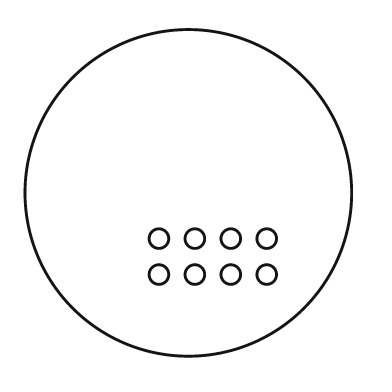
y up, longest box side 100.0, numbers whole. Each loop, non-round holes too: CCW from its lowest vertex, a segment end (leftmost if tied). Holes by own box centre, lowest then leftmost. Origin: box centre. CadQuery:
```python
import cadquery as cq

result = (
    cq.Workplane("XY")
    .moveTo(0.0, 0.0)
    .circle(50.0)
    .moveTo(-9.0, -25.0)
    .circle(3.0)
    .moveTo(2.0, -25.0)
    .circle(3.0)
    .moveTo(13.0, -25.0)
    .circle(3.0)
    .moveTo(24.0, -25.0)
    .circle(3.0)
    .moveTo(-9.0, -14.0)
    .circle(3.0)
    .moveTo(2.0, -14.0)
    .circle(3.0)
    .moveTo(13.0, -14.0)
    .circle(3.0)
    .moveTo(24.0, -14.0)
    .circle(3.0)
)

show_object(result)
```